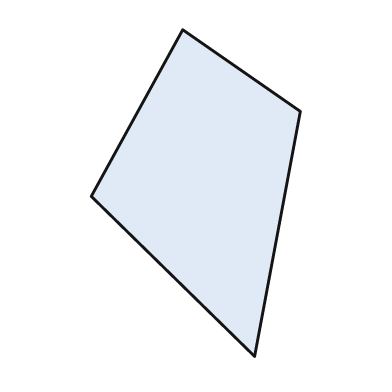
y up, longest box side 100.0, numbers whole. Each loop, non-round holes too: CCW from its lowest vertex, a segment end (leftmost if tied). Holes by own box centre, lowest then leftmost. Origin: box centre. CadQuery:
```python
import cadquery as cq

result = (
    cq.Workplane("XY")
    .moveTo(18.0, -50.0)
    .lineTo(32.0, 25.0)
    .lineTo(-4.0, 50.0)
    .lineTo(-32.0, -1.0)
    .close()
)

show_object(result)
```